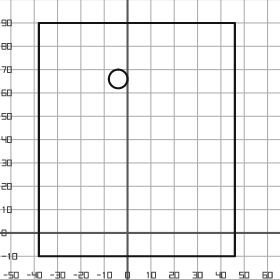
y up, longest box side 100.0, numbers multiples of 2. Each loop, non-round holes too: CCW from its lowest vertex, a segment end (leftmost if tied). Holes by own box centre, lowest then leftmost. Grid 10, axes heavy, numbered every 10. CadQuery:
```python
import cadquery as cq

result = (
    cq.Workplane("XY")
    .moveTo(-38.0, -10.0)
    .lineTo(46.0, -10.0)
    .lineTo(46.0, 90.0)
    .lineTo(-38.0, 90.0)
    .close()
    .moveTo(-4.0, 66.0)
    .circle(4.0)
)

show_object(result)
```